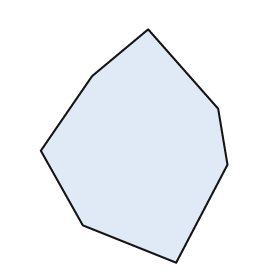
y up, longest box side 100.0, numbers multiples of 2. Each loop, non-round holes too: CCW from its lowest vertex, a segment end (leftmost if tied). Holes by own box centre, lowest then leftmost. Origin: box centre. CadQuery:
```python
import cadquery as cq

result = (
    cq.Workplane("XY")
    .moveTo(18.0, -50.0)
    .lineTo(40.0, -8.0)
    .lineTo(36.0, 16.0)
    .lineTo(6.0, 50.0)
    .lineTo(-18.0, 30.0)
    .lineTo(-40.0, -2.0)
    .lineTo(-22.0, -34.0)
    .close()
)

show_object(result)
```